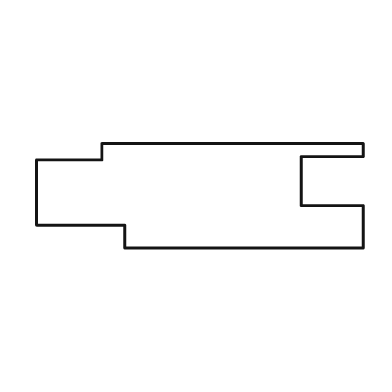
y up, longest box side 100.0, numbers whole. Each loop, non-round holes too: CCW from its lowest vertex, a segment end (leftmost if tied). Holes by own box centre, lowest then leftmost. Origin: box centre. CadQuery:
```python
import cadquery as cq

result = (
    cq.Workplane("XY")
    .moveTo(-23.0, -16.0)
    .lineTo(50.0, -16.0)
    .lineTo(50.0, -3.0)
    .lineTo(31.0, -3.0)
    .lineTo(31.0, 12.0)
    .lineTo(50.0, 12.0)
    .lineTo(50.0, 16.0)
    .lineTo(-30.0, 16.0)
    .lineTo(-30.0, 11.0)
    .lineTo(-50.0, 11.0)
    .lineTo(-50.0, -9.0)
    .lineTo(-23.0, -9.0)
    .close()
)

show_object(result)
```